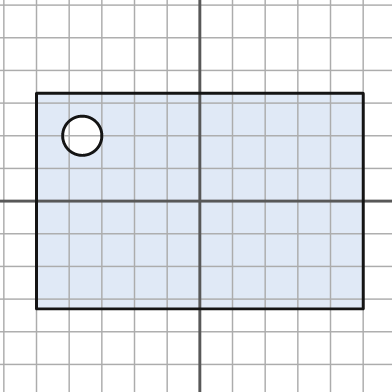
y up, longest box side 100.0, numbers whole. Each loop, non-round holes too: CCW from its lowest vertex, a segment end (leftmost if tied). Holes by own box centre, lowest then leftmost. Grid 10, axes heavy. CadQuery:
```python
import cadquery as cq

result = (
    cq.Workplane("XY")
    .moveTo(-50.0, -33.0)
    .lineTo(50.0, -33.0)
    .lineTo(50.0, 33.0)
    .lineTo(-50.0, 33.0)
    .close()
    .moveTo(-36.0, 20.0)
    .circle(6.0)
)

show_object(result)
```